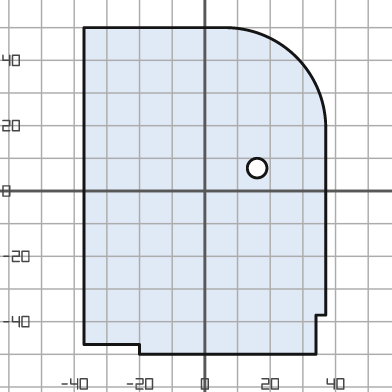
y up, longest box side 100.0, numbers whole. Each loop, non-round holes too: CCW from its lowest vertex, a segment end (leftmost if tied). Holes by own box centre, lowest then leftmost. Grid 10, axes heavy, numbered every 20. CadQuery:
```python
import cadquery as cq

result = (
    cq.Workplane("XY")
    .moveTo(-20.0, -50.0)
    .lineTo(34.0, -50.0)
    .lineTo(34.0, -38.0)
    .lineTo(37.0, -38.0)
    .lineTo(37.0, 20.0)
    .threePointArc((28.0, 41.0), (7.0, 50.0))
    .lineTo(-37.0, 50.0)
    .lineTo(-37.0, -47.0)
    .lineTo(-20.0, -47.0)
    .close()
    .moveTo(16.0, 7.0)
    .circle(3.0)
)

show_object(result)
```